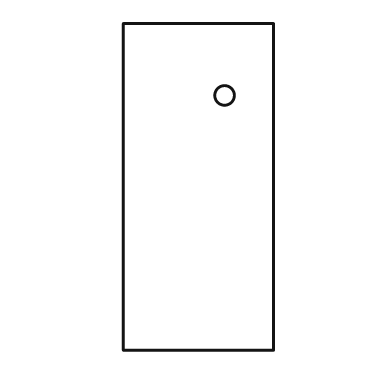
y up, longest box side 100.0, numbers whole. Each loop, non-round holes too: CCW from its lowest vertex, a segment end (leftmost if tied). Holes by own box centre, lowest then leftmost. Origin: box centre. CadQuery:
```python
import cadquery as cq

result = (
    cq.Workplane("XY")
    .moveTo(-23.0, -50.0)
    .lineTo(23.0, -50.0)
    .lineTo(23.0, 50.0)
    .lineTo(-23.0, 50.0)
    .close()
    .moveTo(8.0, 28.0)
    .circle(3.0)
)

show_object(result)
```